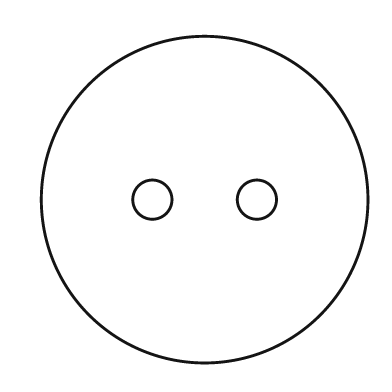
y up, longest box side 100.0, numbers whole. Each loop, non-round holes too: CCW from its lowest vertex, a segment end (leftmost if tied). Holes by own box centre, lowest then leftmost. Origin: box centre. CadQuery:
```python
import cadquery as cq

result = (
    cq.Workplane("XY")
    .moveTo(0.0, 0.0)
    .circle(50.0)
    .moveTo(-16.0, 0.0)
    .circle(6.0)
    .moveTo(16.0, 0.0)
    .circle(6.0)
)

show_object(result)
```